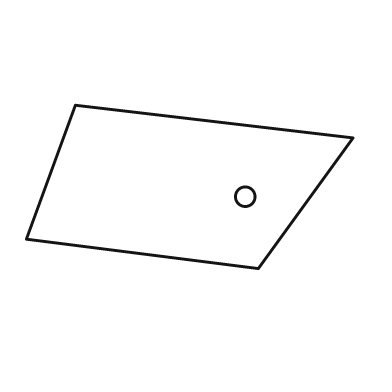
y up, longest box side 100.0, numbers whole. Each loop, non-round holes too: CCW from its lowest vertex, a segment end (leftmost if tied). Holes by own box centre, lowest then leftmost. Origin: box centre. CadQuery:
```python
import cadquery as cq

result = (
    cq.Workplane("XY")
    .moveTo(21.0, -25.0)
    .lineTo(50.0, 15.0)
    .lineTo(-35.0, 25.0)
    .lineTo(-50.0, -16.0)
    .close()
    .moveTo(17.0, -3.0)
    .circle(3.0)
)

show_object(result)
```